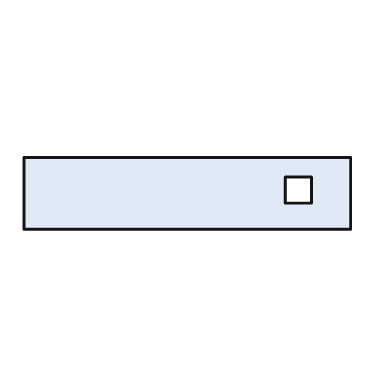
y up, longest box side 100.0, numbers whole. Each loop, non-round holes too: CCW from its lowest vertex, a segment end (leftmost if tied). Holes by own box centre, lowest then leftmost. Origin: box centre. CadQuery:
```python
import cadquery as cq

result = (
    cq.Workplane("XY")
    .moveTo(-50.0, -11.0)
    .lineTo(50.0, -11.0)
    .lineTo(50.0, 11.0)
    .lineTo(-50.0, 11.0)
    .close()
    .moveTo(30.0, -3.0)
    .lineTo(38.0, -3.0)
    .lineTo(38.0, 5.0)
    .lineTo(30.0, 5.0)
    .close()
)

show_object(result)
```